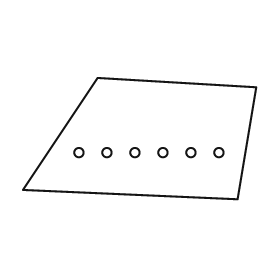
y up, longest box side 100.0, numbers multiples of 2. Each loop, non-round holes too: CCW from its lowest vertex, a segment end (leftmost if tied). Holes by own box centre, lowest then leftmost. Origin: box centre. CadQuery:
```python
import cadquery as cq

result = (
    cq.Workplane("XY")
    .moveTo(42.0, -26.0)
    .lineTo(50.0, 22.0)
    .lineTo(-18.0, 26.0)
    .lineTo(-50.0, -22.0)
    .close()
    .moveTo(-26.0, -6.0)
    .circle(2.0)
    .moveTo(-14.0, -6.0)
    .circle(2.0)
    .moveTo(-2.0, -6.0)
    .circle(2.0)
    .moveTo(10.0, -6.0)
    .circle(2.0)
    .moveTo(22.0, -6.0)
    .circle(2.0)
    .moveTo(34.0, -6.0)
    .circle(2.0)
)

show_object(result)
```